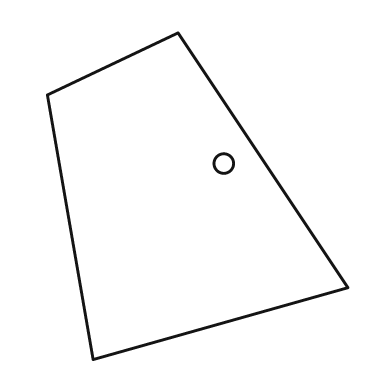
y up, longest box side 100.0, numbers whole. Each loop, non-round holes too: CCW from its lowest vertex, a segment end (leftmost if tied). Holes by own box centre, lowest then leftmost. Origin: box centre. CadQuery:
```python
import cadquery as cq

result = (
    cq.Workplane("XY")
    .moveTo(-32.0, -50.0)
    .lineTo(46.0, -28.0)
    .lineTo(-6.0, 50.0)
    .lineTo(-46.0, 31.0)
    .close()
    .moveTo(8.0, 10.0)
    .circle(3.0)
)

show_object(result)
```